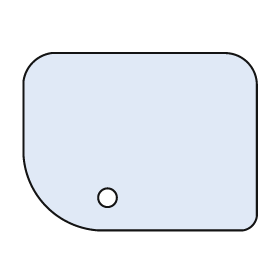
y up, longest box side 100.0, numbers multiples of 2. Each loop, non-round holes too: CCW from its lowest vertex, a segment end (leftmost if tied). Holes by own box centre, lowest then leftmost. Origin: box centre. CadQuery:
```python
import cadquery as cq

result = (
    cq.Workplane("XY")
    .moveTo(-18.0, -38.0)
    .lineTo(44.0, -38.0)
    .threePointArc((48.0, -36.0), (50.0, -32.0))
    .lineTo(50.0, 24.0)
    .threePointArc((46.0, 34.0), (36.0, 38.0))
    .lineTo(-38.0, 38.0)
    .threePointArc((-46.0, 34.0), (-50.0, 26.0))
    .lineTo(-50.0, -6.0)
    .threePointArc((-40.0, -28.0), (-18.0, -38.0))
    .close()
    .moveTo(-14.0, -24.0)
    .circle(4.0)
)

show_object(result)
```